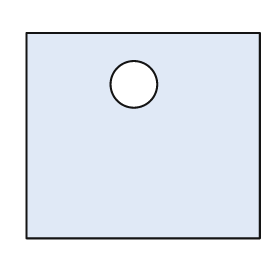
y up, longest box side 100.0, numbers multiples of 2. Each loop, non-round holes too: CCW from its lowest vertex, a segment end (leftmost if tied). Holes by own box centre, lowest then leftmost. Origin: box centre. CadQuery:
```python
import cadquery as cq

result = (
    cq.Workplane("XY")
    .moveTo(-50.0, -44.0)
    .lineTo(50.0, -44.0)
    .lineTo(50.0, 44.0)
    .lineTo(-50.0, 44.0)
    .close()
    .moveTo(-4.0, 22.0)
    .circle(10.0)
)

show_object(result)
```